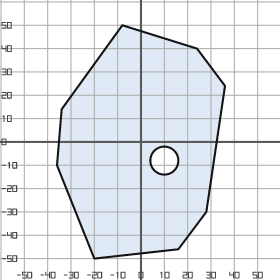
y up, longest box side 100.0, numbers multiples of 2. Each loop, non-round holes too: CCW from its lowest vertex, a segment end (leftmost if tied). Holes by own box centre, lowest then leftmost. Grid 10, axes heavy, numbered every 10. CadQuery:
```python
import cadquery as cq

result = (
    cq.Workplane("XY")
    .moveTo(-20.0, -50.0)
    .lineTo(16.0, -46.0)
    .lineTo(28.0, -30.0)
    .lineTo(36.0, 24.0)
    .lineTo(24.0, 40.0)
    .lineTo(-8.0, 50.0)
    .lineTo(-34.0, 14.0)
    .lineTo(-36.0, -10.0)
    .close()
    .moveTo(10.0, -8.0)
    .circle(6.0)
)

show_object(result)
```